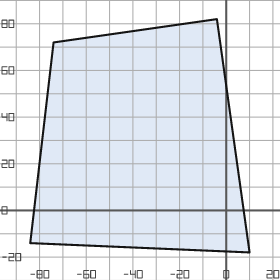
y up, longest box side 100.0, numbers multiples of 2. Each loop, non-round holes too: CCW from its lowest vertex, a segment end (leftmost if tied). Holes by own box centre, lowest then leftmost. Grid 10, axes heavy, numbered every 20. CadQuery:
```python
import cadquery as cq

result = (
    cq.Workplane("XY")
    .moveTo(10.0, -18.0)
    .lineTo(-4.0, 82.0)
    .lineTo(-74.0, 72.0)
    .lineTo(-84.0, -14.0)
    .close()
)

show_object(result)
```